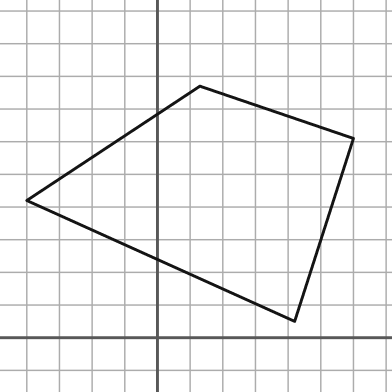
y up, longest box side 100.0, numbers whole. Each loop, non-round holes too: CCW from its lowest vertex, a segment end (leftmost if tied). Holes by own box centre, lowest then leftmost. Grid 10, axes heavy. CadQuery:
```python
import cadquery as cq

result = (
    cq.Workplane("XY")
    .moveTo(42.0, 5.0)
    .lineTo(60.0, 61.0)
    .lineTo(13.0, 77.0)
    .lineTo(-40.0, 42.0)
    .close()
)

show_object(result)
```